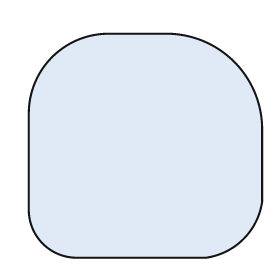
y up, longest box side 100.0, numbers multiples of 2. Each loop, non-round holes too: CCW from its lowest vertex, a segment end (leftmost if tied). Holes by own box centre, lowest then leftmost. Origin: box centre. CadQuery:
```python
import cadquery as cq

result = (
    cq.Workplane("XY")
    .moveTo(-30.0, -48.0)
    .lineTo(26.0, -48.0)
    .threePointArc((42.0, -40.0), (50.0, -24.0))
    .lineTo(50.0, 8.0)
    .threePointArc((38.0, 36.0), (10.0, 48.0))
    .lineTo(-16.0, 48.0)
    .threePointArc((-40.0, 38.0), (-50.0, 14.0))
    .lineTo(-50.0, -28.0)
    .threePointArc((-44.0, -42.0), (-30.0, -48.0))
    .close()
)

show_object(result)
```